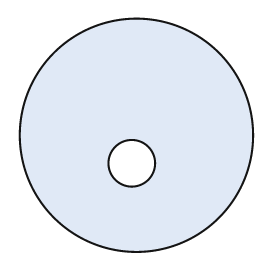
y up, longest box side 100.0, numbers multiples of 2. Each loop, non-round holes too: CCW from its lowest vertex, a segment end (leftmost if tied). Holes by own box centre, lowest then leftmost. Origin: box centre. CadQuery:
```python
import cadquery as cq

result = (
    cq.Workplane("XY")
    .moveTo(0.0, 0.0)
    .circle(50.0)
    .moveTo(-2.0, -12.0)
    .circle(10.0)
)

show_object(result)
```